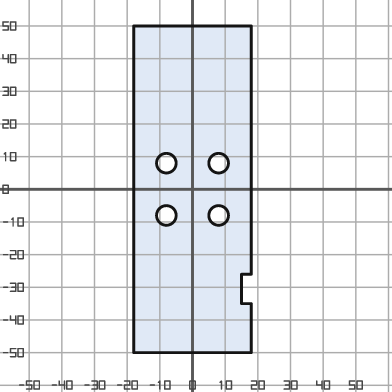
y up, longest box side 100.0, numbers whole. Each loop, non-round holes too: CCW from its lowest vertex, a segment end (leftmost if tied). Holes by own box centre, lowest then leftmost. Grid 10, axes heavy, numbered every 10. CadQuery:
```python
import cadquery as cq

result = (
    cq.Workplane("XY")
    .moveTo(-18.0, -50.0)
    .lineTo(18.0, -50.0)
    .lineTo(18.0, -35.0)
    .lineTo(15.0, -35.0)
    .lineTo(15.0, -26.0)
    .lineTo(18.0, -26.0)
    .lineTo(18.0, 50.0)
    .lineTo(-18.0, 50.0)
    .close()
    .moveTo(-8.0, -8.0)
    .circle(3.0)
    .moveTo(8.0, -8.0)
    .circle(3.0)
    .moveTo(-8.0, 8.0)
    .circle(3.0)
    .moveTo(8.0, 8.0)
    .circle(3.0)
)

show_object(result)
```